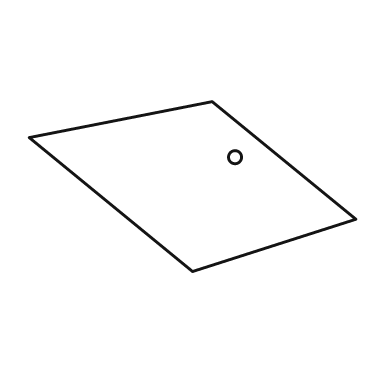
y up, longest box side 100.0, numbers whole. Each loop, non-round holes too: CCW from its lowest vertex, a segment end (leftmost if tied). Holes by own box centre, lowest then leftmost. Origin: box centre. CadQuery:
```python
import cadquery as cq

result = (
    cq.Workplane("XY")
    .moveTo(0.0, -26.0)
    .lineTo(50.0, -10.0)
    .lineTo(6.0, 26.0)
    .lineTo(-50.0, 15.0)
    .close()
    .moveTo(13.0, 9.0)
    .circle(2.0)
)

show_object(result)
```